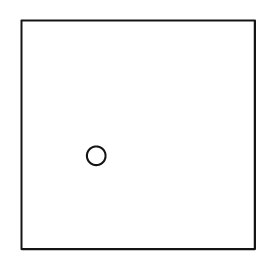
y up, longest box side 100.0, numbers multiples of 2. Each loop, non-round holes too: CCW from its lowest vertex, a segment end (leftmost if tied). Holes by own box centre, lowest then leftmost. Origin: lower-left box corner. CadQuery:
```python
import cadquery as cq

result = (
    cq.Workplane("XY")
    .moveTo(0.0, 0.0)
    .lineTo(100.0, 0.0)
    .lineTo(100.0, 98.0)
    .lineTo(0.0, 98.0)
    .close()
    .moveTo(32.0, 40.0)
    .circle(4.0)
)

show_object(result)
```